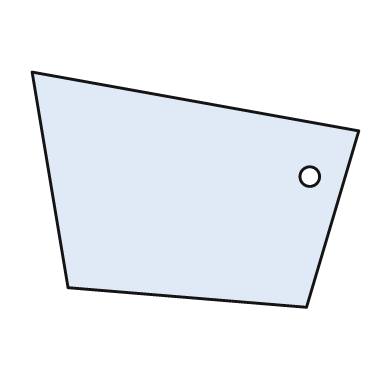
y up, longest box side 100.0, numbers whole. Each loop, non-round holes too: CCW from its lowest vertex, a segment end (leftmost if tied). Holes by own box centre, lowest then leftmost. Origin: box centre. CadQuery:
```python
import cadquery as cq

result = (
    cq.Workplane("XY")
    .moveTo(34.0, -36.0)
    .lineTo(50.0, 18.0)
    .lineTo(-50.0, 36.0)
    .lineTo(-39.0, -30.0)
    .close()
    .moveTo(35.0, 4.0)
    .circle(3.0)
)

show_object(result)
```